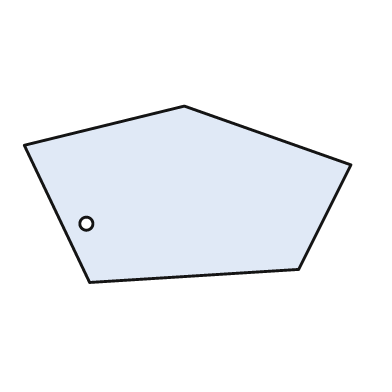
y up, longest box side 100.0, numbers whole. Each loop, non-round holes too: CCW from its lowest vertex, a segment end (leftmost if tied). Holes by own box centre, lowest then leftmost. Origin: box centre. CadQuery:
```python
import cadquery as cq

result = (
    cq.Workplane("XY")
    .moveTo(-30.0, -27.0)
    .lineTo(34.0, -23.0)
    .lineTo(50.0, 9.0)
    .lineTo(-1.0, 27.0)
    .lineTo(-50.0, 15.0)
    .close()
    .moveTo(-31.0, -9.0)
    .circle(2.0)
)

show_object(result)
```